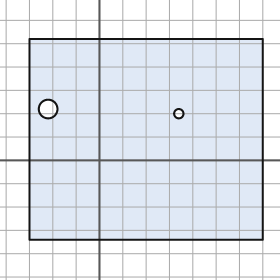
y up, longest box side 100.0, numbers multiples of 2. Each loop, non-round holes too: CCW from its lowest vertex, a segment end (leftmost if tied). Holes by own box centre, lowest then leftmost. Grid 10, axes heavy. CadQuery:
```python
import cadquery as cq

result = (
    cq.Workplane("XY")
    .moveTo(-30.0, -34.0)
    .lineTo(70.0, -34.0)
    .lineTo(70.0, 52.0)
    .lineTo(-30.0, 52.0)
    .close()
    .moveTo(34.0, 20.0)
    .circle(2.0)
    .moveTo(-22.0, 22.0)
    .circle(4.0)
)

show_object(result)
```